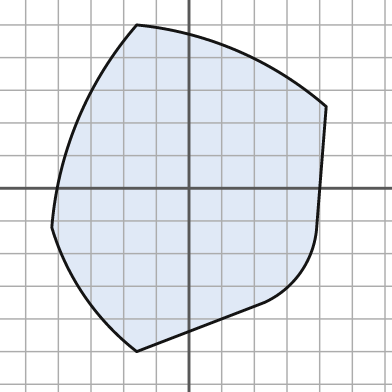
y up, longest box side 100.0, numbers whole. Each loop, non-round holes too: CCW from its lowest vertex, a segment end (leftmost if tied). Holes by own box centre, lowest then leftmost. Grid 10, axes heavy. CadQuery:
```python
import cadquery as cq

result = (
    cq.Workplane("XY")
    .moveTo(-16.0, -50.0)
    .lineTo(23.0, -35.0)
    .threePointArc((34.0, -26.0), (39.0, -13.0))
    .lineTo(42.0, 25.0)
    .threePointArc((15.0, 42.0), (-16.0, 50.0))
    .threePointArc((-34.0, 21.0), (-42.0, -12.0))
    .threePointArc((-32.0, -33.0), (-16.0, -50.0))
    .close()
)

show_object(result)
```